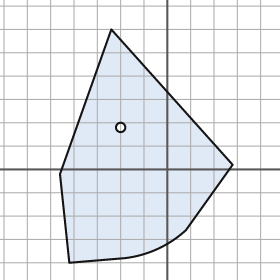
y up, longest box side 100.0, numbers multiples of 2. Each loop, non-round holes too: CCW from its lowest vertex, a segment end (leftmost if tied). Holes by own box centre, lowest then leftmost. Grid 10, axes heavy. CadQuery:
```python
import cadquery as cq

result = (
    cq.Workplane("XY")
    .moveTo(-42.0, -40.0)
    .lineTo(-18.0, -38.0)
    .threePointArc((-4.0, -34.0), (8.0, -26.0))
    .lineTo(28.0, 2.0)
    .lineTo(-24.0, 60.0)
    .lineTo(-46.0, -2.0)
    .close()
    .moveTo(-20.0, 18.0)
    .circle(2.0)
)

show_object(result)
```